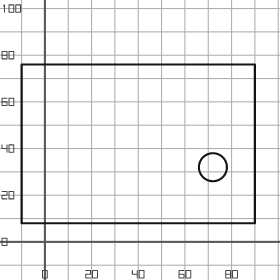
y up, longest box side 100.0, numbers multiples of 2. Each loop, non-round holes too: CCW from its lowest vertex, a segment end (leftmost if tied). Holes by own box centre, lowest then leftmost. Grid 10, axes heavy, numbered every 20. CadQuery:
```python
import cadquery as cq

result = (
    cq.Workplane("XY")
    .moveTo(-10.0, 8.0)
    .lineTo(90.0, 8.0)
    .lineTo(90.0, 76.0)
    .lineTo(-10.0, 76.0)
    .close()
    .moveTo(72.0, 32.0)
    .circle(6.0)
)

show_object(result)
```